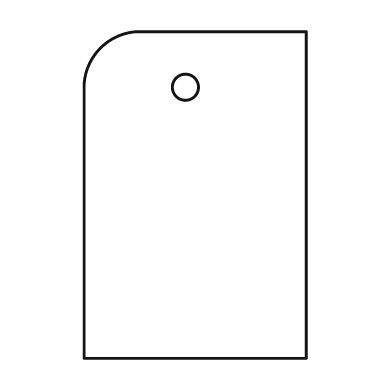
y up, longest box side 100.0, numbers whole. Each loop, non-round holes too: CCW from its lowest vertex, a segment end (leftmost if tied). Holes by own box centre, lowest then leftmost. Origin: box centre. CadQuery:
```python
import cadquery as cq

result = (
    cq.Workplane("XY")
    .moveTo(-34.0, -50.0)
    .lineTo(34.0, -50.0)
    .lineTo(34.0, 50.0)
    .lineTo(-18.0, 50.0)
    .threePointArc((-29.0, 45.0), (-34.0, 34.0))
    .close()
    .moveTo(-3.0, 33.0)
    .circle(4.0)
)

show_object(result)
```